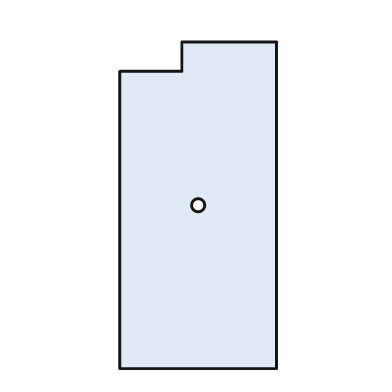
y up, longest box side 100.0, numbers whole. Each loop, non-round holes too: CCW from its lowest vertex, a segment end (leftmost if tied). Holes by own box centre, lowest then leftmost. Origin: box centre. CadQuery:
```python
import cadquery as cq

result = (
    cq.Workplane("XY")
    .moveTo(-24.0, -50.0)
    .lineTo(24.0, -50.0)
    .lineTo(24.0, 50.0)
    .lineTo(-5.0, 50.0)
    .lineTo(-5.0, 41.0)
    .lineTo(-24.0, 41.0)
    .close()
    .moveTo(0.0, 0.0)
    .circle(2.0)
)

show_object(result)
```